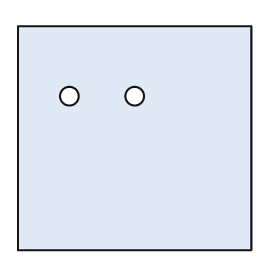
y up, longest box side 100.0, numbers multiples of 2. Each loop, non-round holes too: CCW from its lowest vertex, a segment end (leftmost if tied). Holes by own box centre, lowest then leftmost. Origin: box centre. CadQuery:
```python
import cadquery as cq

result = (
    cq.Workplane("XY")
    .moveTo(-50.0, -48.0)
    .lineTo(50.0, -48.0)
    .lineTo(50.0, 48.0)
    .lineTo(-50.0, 48.0)
    .close()
    .moveTo(-28.0, 18.0)
    .circle(4.0)
    .moveTo(0.0, 18.0)
    .circle(4.0)
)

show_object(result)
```